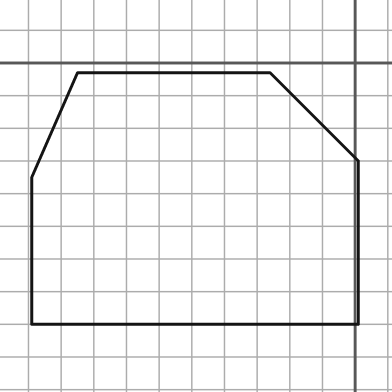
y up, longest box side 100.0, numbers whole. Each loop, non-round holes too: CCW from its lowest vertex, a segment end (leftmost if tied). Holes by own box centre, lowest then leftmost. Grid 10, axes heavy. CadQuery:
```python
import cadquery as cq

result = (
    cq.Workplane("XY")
    .moveTo(-99.0, -80.0)
    .lineTo(1.0, -80.0)
    .lineTo(1.0, -30.0)
    .lineTo(-26.0, -3.0)
    .lineTo(-85.0, -3.0)
    .lineTo(-99.0, -35.0)
    .close()
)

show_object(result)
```